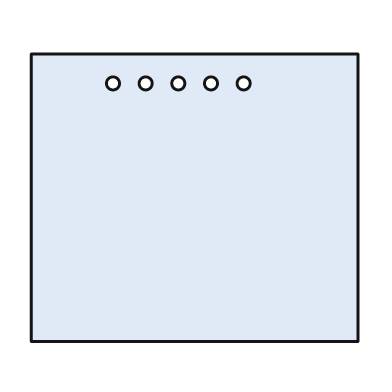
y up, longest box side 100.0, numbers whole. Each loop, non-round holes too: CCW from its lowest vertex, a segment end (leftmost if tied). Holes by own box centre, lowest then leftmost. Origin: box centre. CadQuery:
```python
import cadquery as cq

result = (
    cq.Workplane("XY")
    .moveTo(-50.0, -44.0)
    .lineTo(50.0, -44.0)
    .lineTo(50.0, 44.0)
    .lineTo(-50.0, 44.0)
    .close()
    .moveTo(-25.0, 35.0)
    .circle(2.0)
    .moveTo(-15.0, 35.0)
    .circle(2.0)
    .moveTo(-5.0, 35.0)
    .circle(2.0)
    .moveTo(5.0, 35.0)
    .circle(2.0)
    .moveTo(15.0, 35.0)
    .circle(2.0)
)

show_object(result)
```